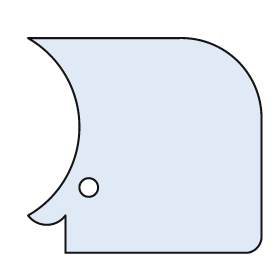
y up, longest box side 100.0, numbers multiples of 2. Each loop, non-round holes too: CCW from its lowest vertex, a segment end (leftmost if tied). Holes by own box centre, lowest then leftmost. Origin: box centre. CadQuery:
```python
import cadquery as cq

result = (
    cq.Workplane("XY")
    .moveTo(-34.0, -46.0)
    .lineTo(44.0, -46.0)
    .threePointArc((48.0, -44.0), (50.0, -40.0))
    .lineTo(50.0, 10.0)
    .threePointArc((40.0, 36.0), (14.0, 46.0))
    .lineTo(-50.0, 46.0)
    .threePointArc((-28.0, 8.0), (-50.0, -30.0))
    .threePointArc((-42.0, -34.0), (-34.0, -30.0))
    .close()
    .moveTo(-24.0, -18.0)
    .circle(4.0)
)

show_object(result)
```